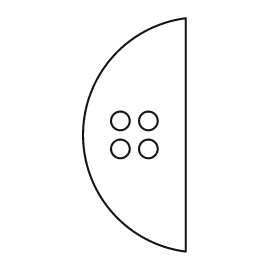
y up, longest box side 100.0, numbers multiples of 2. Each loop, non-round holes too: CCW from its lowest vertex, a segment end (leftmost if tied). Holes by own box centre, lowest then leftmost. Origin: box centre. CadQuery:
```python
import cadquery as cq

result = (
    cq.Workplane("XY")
    .moveTo(22.0, -50.0)
    .lineTo(22.0, 50.0)
    .threePointArc((-22.0, 0.0), (22.0, -50.0))
    .close()
    .moveTo(-6.0, -6.0)
    .circle(4.0)
    .moveTo(6.0, -6.0)
    .circle(4.0)
    .moveTo(-6.0, 6.0)
    .circle(4.0)
    .moveTo(6.0, 6.0)
    .circle(4.0)
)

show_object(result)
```